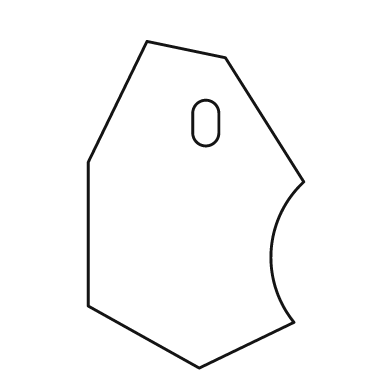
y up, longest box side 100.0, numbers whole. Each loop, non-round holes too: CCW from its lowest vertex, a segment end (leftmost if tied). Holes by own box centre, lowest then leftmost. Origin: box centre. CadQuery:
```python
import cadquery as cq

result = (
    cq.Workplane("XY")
    .moveTo(1.0, -50.0)
    .lineTo(30.0, -36.0)
    .threePointArc((23.0, -14.0), (33.0, 7.0))
    .lineTo(9.0, 45.0)
    .lineTo(-15.0, 50.0)
    .lineTo(-33.0, 13.0)
    .lineTo(-33.0, -31.0)
    .close()
    .moveTo(-1.0, 22.0)
    .threePointArc((3.0, 18.0), (7.0, 22.0))
    .lineTo(7.0, 28.0)
    .threePointArc((3.0, 32.0), (-1.0, 28.0))
    .close()
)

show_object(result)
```